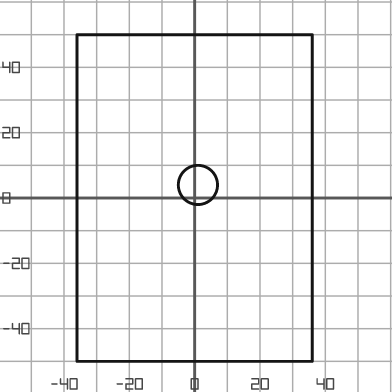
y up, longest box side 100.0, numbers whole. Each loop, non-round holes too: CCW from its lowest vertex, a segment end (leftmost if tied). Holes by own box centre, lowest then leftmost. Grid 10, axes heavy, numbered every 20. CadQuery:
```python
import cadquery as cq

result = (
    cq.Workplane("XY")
    .moveTo(-36.0, -50.0)
    .lineTo(36.0, -50.0)
    .lineTo(36.0, 50.0)
    .lineTo(-36.0, 50.0)
    .close()
    .moveTo(1.0, 4.0)
    .circle(6.0)
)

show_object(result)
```